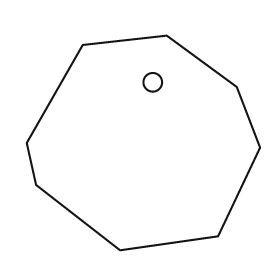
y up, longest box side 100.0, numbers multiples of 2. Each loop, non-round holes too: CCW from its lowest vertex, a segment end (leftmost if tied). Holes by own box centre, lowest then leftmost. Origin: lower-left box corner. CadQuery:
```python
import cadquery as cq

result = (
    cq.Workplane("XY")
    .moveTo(40.0, 0.0)
    .lineTo(82.0, 6.0)
    .lineTo(100.0, 44.0)
    .lineTo(90.0, 70.0)
    .lineTo(60.0, 92.0)
    .lineTo(24.0, 88.0)
    .lineTo(0.0, 46.0)
    .lineTo(4.0, 28.0)
    .close()
    .moveTo(54.0, 72.0)
    .circle(4.0)
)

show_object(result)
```